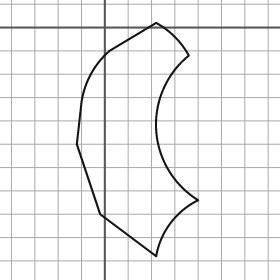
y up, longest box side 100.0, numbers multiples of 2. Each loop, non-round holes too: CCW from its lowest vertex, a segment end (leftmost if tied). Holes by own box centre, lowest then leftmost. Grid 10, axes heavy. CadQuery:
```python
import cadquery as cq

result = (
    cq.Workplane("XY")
    .moveTo(22.0, -98.0)
    .threePointArc((28.0, -84.0), (40.0, -74.0))
    .threePointArc((22.0, -44.0), (36.0, -12.0))
    .threePointArc((30.0, -4.0), (22.0, 2.0))
    .lineTo(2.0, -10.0)
    .threePointArc((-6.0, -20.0), (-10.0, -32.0))
    .lineTo(-12.0, -50.0)
    .lineTo(-2.0, -80.0)
    .close()
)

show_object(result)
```